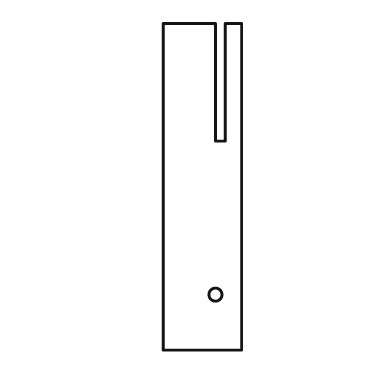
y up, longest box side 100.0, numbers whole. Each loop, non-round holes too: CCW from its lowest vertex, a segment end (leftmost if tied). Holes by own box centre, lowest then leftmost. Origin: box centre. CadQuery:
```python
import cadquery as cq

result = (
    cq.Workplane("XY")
    .moveTo(-12.0, -50.0)
    .lineTo(12.0, -50.0)
    .lineTo(12.0, 50.0)
    .lineTo(7.0, 50.0)
    .lineTo(7.0, 14.0)
    .lineTo(4.0, 14.0)
    .lineTo(4.0, 50.0)
    .lineTo(-12.0, 50.0)
    .close()
    .moveTo(4.0, -33.0)
    .circle(2.0)
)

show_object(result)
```